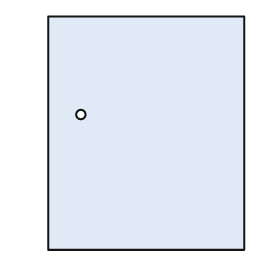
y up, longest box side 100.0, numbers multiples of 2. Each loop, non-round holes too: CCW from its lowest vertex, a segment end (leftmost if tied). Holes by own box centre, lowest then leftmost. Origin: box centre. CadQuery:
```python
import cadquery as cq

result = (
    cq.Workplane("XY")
    .moveTo(-42.0, -50.0)
    .lineTo(42.0, -50.0)
    .lineTo(42.0, 50.0)
    .lineTo(-42.0, 50.0)
    .close()
    .moveTo(-28.0, 8.0)
    .circle(2.0)
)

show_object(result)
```